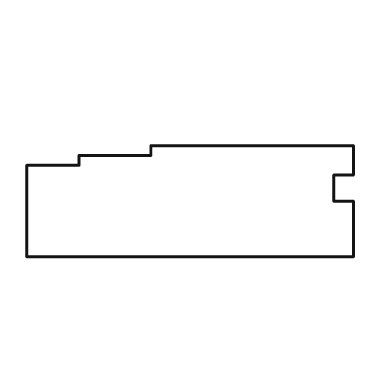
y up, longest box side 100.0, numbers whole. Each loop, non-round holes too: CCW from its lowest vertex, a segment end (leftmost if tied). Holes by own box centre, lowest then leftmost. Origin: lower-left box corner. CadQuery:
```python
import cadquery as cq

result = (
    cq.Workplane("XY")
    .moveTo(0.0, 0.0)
    .lineTo(100.0, 0.0)
    .lineTo(100.0, 17.0)
    .lineTo(94.0, 17.0)
    .lineTo(94.0, 25.0)
    .lineTo(100.0, 25.0)
    .lineTo(100.0, 34.0)
    .lineTo(38.0, 34.0)
    .lineTo(38.0, 31.0)
    .lineTo(16.0, 31.0)
    .lineTo(16.0, 28.0)
    .lineTo(0.0, 28.0)
    .close()
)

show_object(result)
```